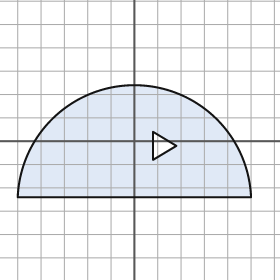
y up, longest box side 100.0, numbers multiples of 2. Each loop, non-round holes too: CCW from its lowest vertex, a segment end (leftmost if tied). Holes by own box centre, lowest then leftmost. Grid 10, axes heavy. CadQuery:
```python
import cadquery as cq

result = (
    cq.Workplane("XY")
    .moveTo(-50.0, -24.0)
    .lineTo(50.0, -24.0)
    .threePointArc((0.0, 24.0), (-50.0, -24.0))
    .close()
    .moveTo(8.0, -8.0)
    .lineTo(18.0, -2.0)
    .lineTo(8.0, 4.0)
    .close()
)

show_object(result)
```